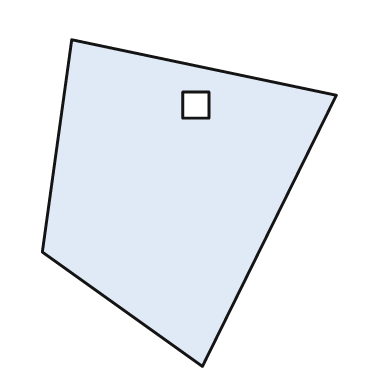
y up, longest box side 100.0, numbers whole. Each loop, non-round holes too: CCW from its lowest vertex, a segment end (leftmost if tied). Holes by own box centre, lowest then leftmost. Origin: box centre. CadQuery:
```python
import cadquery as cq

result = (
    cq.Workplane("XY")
    .moveTo(4.0, -50.0)
    .lineTo(45.0, 33.0)
    .lineTo(-36.0, 50.0)
    .lineTo(-45.0, -15.0)
    .close()
    .moveTo(-2.0, 26.0)
    .lineTo(6.0, 26.0)
    .lineTo(6.0, 34.0)
    .lineTo(-2.0, 34.0)
    .close()
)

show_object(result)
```